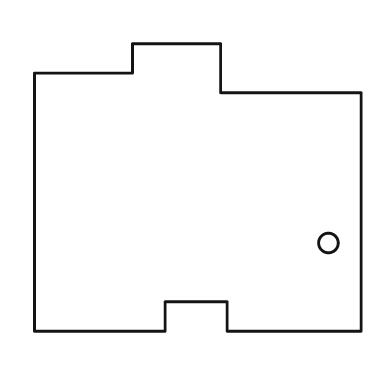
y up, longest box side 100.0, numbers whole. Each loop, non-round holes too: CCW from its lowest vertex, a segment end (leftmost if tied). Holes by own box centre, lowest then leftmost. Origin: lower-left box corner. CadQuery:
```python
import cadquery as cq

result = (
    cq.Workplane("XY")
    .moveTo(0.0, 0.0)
    .lineTo(40.0, 0.0)
    .lineTo(40.0, 9.0)
    .lineTo(59.0, 9.0)
    .lineTo(59.0, 0.0)
    .lineTo(100.0, 0.0)
    .lineTo(100.0, 73.0)
    .lineTo(57.0, 73.0)
    .lineTo(57.0, 88.0)
    .lineTo(30.0, 88.0)
    .lineTo(30.0, 79.0)
    .lineTo(0.0, 79.0)
    .close()
    .moveTo(90.0, 27.0)
    .circle(3.0)
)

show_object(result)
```